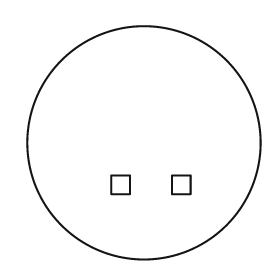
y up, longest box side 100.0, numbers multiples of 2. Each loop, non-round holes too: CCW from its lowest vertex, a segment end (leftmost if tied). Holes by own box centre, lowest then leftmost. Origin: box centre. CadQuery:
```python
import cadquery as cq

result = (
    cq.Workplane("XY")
    .moveTo(0.0, 0.0)
    .circle(50.0)
    .moveTo(-14.0, -22.0)
    .lineTo(-6.0, -22.0)
    .lineTo(-6.0, -14.0)
    .lineTo(-14.0, -14.0)
    .close()
    .moveTo(12.0, -22.0)
    .lineTo(20.0, -22.0)
    .lineTo(20.0, -14.0)
    .lineTo(12.0, -14.0)
    .close()
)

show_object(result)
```